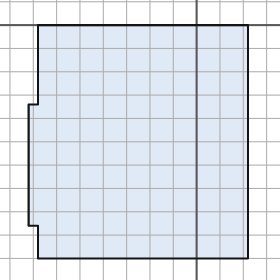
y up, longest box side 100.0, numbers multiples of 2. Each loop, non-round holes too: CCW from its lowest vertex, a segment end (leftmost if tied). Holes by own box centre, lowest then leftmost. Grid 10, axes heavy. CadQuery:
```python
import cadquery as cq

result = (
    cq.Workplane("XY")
    .moveTo(-68.0, -100.0)
    .lineTo(22.0, -100.0)
    .lineTo(22.0, 0.0)
    .lineTo(-68.0, 0.0)
    .lineTo(-68.0, -34.0)
    .lineTo(-72.0, -34.0)
    .lineTo(-72.0, -86.0)
    .lineTo(-68.0, -86.0)
    .close()
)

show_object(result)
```